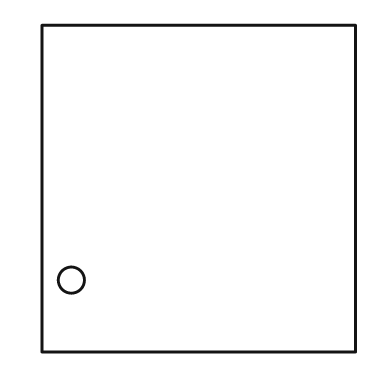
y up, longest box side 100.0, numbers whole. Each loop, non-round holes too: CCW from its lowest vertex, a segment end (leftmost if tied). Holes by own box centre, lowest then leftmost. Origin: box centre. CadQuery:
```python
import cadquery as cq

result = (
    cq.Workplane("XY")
    .moveTo(-48.0, -50.0)
    .lineTo(48.0, -50.0)
    .lineTo(48.0, 50.0)
    .lineTo(-48.0, 50.0)
    .close()
    .moveTo(-39.0, -28.0)
    .circle(4.0)
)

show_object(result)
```